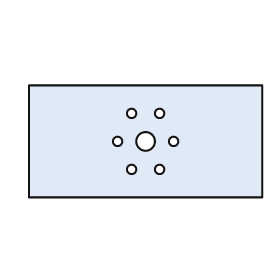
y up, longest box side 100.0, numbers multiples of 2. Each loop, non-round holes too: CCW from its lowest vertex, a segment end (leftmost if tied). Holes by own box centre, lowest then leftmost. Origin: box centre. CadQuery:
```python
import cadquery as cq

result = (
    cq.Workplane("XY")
    .moveTo(-50.0, -24.0)
    .lineTo(50.0, -24.0)
    .lineTo(50.0, 24.0)
    .lineTo(-50.0, 24.0)
    .close()
    .moveTo(-6.0, -12.0)
    .circle(2.0)
    .moveTo(6.0, -12.0)
    .circle(2.0)
    .moveTo(-12.0, 0.0)
    .circle(2.0)
    .moveTo(0.0, 0.0)
    .circle(4.0)
    .moveTo(12.0, 0.0)
    .circle(2.0)
    .moveTo(-6.0, 12.0)
    .circle(2.0)
    .moveTo(6.0, 12.0)
    .circle(2.0)
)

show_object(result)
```